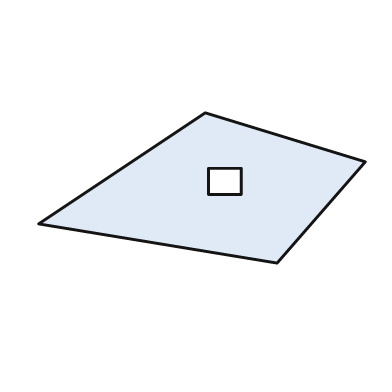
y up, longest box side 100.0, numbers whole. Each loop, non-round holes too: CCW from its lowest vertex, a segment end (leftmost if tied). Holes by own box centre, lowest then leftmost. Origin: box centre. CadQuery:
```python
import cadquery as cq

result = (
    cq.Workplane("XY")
    .moveTo(23.0, -23.0)
    .lineTo(50.0, 8.0)
    .lineTo(1.0, 23.0)
    .lineTo(-50.0, -11.0)
    .close()
    .moveTo(2.0, -2.0)
    .lineTo(12.0, -2.0)
    .lineTo(12.0, 6.0)
    .lineTo(2.0, 6.0)
    .close()
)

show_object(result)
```